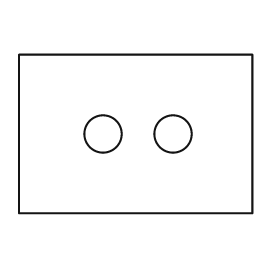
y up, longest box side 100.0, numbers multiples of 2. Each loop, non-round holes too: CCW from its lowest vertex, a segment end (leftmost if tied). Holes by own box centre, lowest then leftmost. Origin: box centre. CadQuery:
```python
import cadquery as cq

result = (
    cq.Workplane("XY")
    .moveTo(-50.0, -34.0)
    .lineTo(50.0, -34.0)
    .lineTo(50.0, 34.0)
    .lineTo(-50.0, 34.0)
    .close()
    .moveTo(-14.0, 0.0)
    .circle(8.0)
    .moveTo(16.0, 0.0)
    .circle(8.0)
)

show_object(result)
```